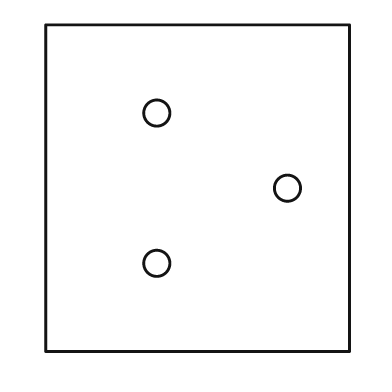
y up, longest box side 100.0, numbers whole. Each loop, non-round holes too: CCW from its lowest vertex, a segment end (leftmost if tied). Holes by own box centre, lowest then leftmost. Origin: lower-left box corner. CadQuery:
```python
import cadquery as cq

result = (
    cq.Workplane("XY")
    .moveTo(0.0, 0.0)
    .lineTo(93.0, 0.0)
    .lineTo(93.0, 100.0)
    .lineTo(0.0, 100.0)
    .close()
    .moveTo(34.0, 27.0)
    .circle(4.0)
    .moveTo(74.0, 50.0)
    .circle(4.0)
    .moveTo(34.0, 73.0)
    .circle(4.0)
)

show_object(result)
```